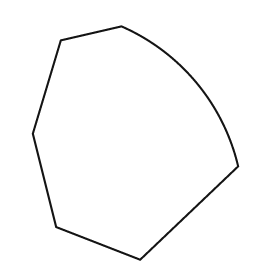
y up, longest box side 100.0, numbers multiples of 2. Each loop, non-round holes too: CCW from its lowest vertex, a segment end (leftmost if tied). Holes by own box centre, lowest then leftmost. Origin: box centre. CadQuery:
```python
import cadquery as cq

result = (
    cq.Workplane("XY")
    .moveTo(2.0, -50.0)
    .lineTo(44.0, -10.0)
    .threePointArc((26.0, 26.0), (-6.0, 50.0))
    .lineTo(-32.0, 44.0)
    .lineTo(-44.0, 4.0)
    .lineTo(-34.0, -36.0)
    .close()
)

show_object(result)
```